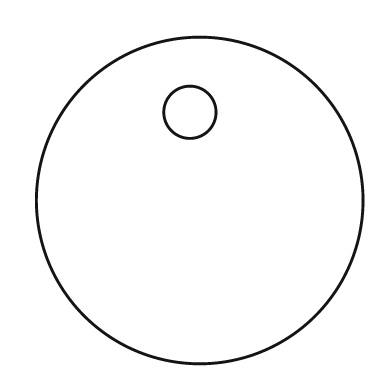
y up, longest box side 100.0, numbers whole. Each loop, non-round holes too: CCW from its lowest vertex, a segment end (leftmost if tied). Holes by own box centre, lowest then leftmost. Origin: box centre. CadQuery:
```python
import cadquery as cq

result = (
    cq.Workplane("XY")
    .moveTo(0.0, 0.0)
    .circle(50.0)
    .moveTo(-3.0, 27.0)
    .circle(8.0)
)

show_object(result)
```